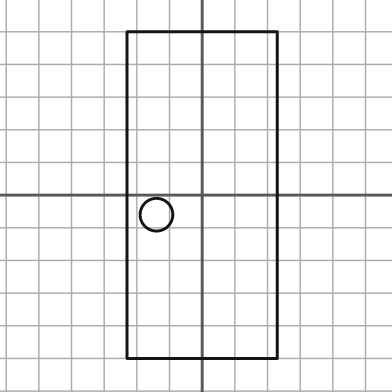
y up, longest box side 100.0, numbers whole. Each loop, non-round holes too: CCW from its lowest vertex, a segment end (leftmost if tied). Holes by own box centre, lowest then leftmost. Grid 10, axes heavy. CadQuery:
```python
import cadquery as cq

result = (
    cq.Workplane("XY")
    .moveTo(-23.0, -50.0)
    .lineTo(23.0, -50.0)
    .lineTo(23.0, 50.0)
    .lineTo(-23.0, 50.0)
    .close()
    .moveTo(-14.0, -6.0)
    .circle(5.0)
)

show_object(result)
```